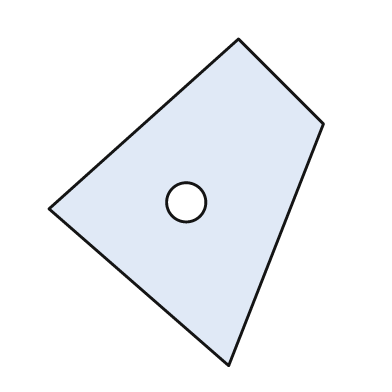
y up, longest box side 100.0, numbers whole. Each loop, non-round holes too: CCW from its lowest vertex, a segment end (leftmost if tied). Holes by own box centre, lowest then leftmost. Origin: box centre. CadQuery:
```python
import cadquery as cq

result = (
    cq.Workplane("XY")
    .moveTo(13.0, -50.0)
    .lineTo(42.0, 24.0)
    .lineTo(16.0, 50.0)
    .lineTo(-42.0, -2.0)
    .close()
    .moveTo(0.0, 0.0)
    .circle(6.0)
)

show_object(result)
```